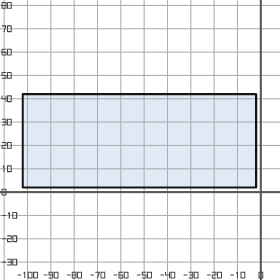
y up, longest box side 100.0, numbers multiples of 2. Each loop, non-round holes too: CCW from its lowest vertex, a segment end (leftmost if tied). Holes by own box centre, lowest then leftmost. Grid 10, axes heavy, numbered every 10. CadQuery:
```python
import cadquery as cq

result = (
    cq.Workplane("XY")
    .moveTo(-102.0, 2.0)
    .lineTo(-2.0, 2.0)
    .lineTo(-2.0, 42.0)
    .lineTo(-102.0, 42.0)
    .close()
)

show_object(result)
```